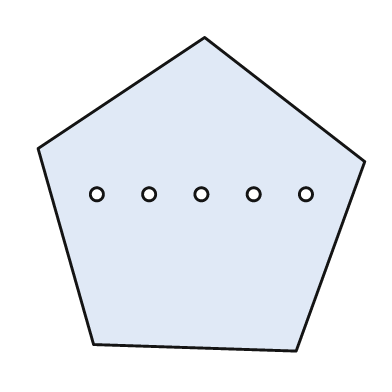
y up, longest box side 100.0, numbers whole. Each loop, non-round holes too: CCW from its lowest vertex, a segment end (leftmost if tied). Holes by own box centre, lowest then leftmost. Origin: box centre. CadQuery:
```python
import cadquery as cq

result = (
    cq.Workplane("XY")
    .moveTo(29.0, -48.0)
    .lineTo(50.0, 10.0)
    .lineTo(1.0, 48.0)
    .lineTo(-50.0, 14.0)
    .lineTo(-33.0, -46.0)
    .close()
    .moveTo(-32.0, 0.0)
    .circle(2.0)
    .moveTo(-16.0, 0.0)
    .circle(2.0)
    .moveTo(0.0, 0.0)
    .circle(2.0)
    .moveTo(16.0, 0.0)
    .circle(2.0)
    .moveTo(32.0, 0.0)
    .circle(2.0)
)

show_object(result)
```